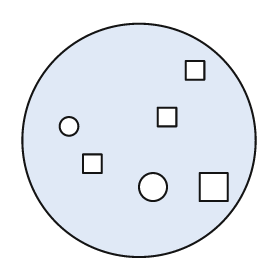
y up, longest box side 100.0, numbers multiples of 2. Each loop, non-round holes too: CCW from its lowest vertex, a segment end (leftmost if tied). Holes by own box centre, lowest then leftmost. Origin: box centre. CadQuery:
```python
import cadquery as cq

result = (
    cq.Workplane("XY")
    .moveTo(0.0, 0.0)
    .circle(50.0)
    .moveTo(6.0, -20.0)
    .circle(6.0)
    .moveTo(26.0, -26.0)
    .lineTo(38.0, -26.0)
    .lineTo(38.0, -14.0)
    .lineTo(26.0, -14.0)
    .close()
    .moveTo(-24.0, -14.0)
    .lineTo(-16.0, -14.0)
    .lineTo(-16.0, -6.0)
    .lineTo(-24.0, -6.0)
    .close()
    .moveTo(-30.0, 6.0)
    .circle(4.0)
    .moveTo(8.0, 6.0)
    .lineTo(16.0, 6.0)
    .lineTo(16.0, 14.0)
    .lineTo(8.0, 14.0)
    .close()
    .moveTo(20.0, 26.0)
    .lineTo(28.0, 26.0)
    .lineTo(28.0, 34.0)
    .lineTo(20.0, 34.0)
    .close()
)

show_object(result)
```